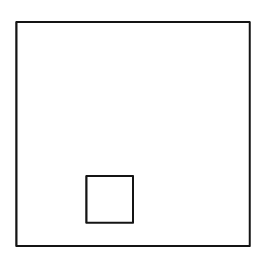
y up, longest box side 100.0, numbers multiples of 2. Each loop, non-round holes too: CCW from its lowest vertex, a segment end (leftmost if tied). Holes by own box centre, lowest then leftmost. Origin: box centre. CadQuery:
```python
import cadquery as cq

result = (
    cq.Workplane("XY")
    .moveTo(-50.0, -48.0)
    .lineTo(50.0, -48.0)
    .lineTo(50.0, 48.0)
    .lineTo(-50.0, 48.0)
    .close()
    .moveTo(-20.0, -38.0)
    .lineTo(0.0, -38.0)
    .lineTo(0.0, -18.0)
    .lineTo(-20.0, -18.0)
    .close()
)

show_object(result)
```